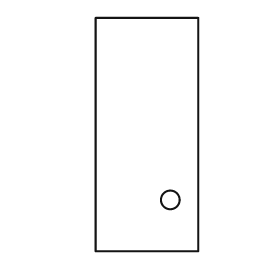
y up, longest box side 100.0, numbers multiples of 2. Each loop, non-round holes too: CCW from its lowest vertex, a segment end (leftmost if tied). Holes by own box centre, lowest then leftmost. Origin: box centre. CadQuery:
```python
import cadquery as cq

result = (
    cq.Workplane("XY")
    .moveTo(-22.0, -50.0)
    .lineTo(22.0, -50.0)
    .lineTo(22.0, 50.0)
    .lineTo(-22.0, 50.0)
    .close()
    .moveTo(10.0, -28.0)
    .circle(4.0)
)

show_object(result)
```